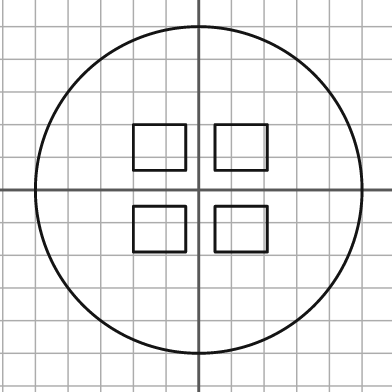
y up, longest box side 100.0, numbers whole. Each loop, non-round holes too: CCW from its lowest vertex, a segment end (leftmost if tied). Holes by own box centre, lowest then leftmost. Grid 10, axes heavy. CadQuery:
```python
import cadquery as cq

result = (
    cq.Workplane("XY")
    .moveTo(0.0, 0.0)
    .circle(50.0)
    .moveTo(-20.0, -19.0)
    .lineTo(-4.0, -19.0)
    .lineTo(-4.0, -5.0)
    .lineTo(-20.0, -5.0)
    .close()
    .moveTo(5.0, -19.0)
    .lineTo(21.0, -19.0)
    .lineTo(21.0, -5.0)
    .lineTo(5.0, -5.0)
    .close()
    .moveTo(-20.0, 6.0)
    .lineTo(-4.0, 6.0)
    .lineTo(-4.0, 20.0)
    .lineTo(-20.0, 20.0)
    .close()
    .moveTo(5.0, 6.0)
    .lineTo(21.0, 6.0)
    .lineTo(21.0, 20.0)
    .lineTo(5.0, 20.0)
    .close()
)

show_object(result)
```